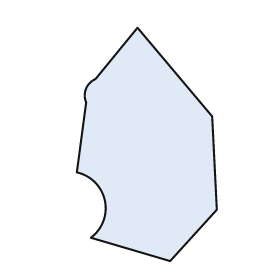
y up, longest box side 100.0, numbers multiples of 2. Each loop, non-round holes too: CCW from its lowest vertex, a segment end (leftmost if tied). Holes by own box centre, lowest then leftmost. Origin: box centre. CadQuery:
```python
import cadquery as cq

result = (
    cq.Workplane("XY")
    .moveTo(10.0, -50.0)
    .lineTo(30.0, -28.0)
    .lineTo(28.0, 12.0)
    .lineTo(-4.0, 50.0)
    .lineTo(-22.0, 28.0)
    .threePointArc((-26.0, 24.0), (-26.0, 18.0))
    .lineTo(-30.0, -12.0)
    .threePointArc((-18.0, -24.0), (-24.0, -40.0))
    .close()
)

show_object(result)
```